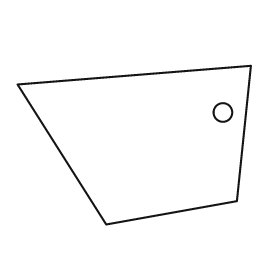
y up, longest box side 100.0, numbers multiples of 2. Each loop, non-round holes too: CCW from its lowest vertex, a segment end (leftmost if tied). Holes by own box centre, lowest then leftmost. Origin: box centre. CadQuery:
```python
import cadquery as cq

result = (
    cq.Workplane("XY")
    .moveTo(-12.0, -34.0)
    .lineTo(44.0, -24.0)
    .lineTo(50.0, 34.0)
    .lineTo(-50.0, 26.0)
    .close()
    .moveTo(38.0, 14.0)
    .circle(4.0)
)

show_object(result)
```